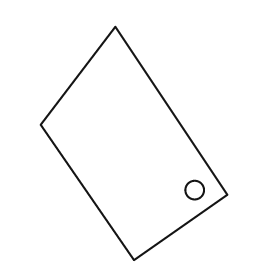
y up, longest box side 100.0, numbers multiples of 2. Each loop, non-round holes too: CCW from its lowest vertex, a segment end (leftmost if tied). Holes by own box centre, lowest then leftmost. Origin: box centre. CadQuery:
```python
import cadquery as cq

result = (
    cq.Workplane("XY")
    .moveTo(0.0, -50.0)
    .lineTo(40.0, -22.0)
    .lineTo(-8.0, 50.0)
    .lineTo(-40.0, 8.0)
    .close()
    .moveTo(26.0, -20.0)
    .circle(4.0)
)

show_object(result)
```